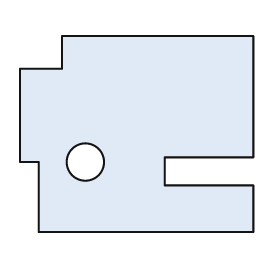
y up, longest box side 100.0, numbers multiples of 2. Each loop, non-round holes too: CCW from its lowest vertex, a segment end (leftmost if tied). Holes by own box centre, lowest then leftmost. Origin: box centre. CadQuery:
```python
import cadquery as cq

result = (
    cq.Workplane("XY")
    .moveTo(-42.0, -42.0)
    .lineTo(50.0, -42.0)
    .lineTo(50.0, -22.0)
    .lineTo(12.0, -22.0)
    .lineTo(12.0, -10.0)
    .lineTo(50.0, -10.0)
    .lineTo(50.0, 42.0)
    .lineTo(-32.0, 42.0)
    .lineTo(-32.0, 28.0)
    .lineTo(-50.0, 28.0)
    .lineTo(-50.0, -12.0)
    .lineTo(-42.0, -12.0)
    .close()
    .moveTo(-22.0, -12.0)
    .circle(8.0)
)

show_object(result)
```